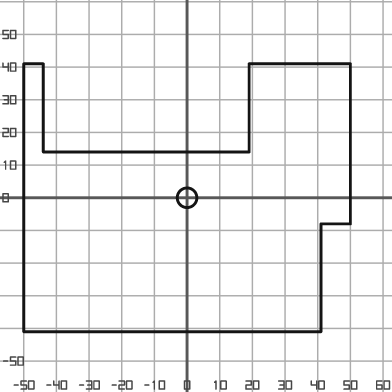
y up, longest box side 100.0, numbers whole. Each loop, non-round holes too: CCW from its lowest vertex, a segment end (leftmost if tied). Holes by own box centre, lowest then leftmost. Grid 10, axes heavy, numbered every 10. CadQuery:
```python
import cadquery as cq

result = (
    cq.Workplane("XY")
    .moveTo(-50.0, -41.0)
    .lineTo(41.0, -41.0)
    .lineTo(41.0, -8.0)
    .lineTo(50.0, -8.0)
    .lineTo(50.0, 41.0)
    .lineTo(19.0, 41.0)
    .lineTo(19.0, 14.0)
    .lineTo(-44.0, 14.0)
    .lineTo(-44.0, 41.0)
    .lineTo(-50.0, 41.0)
    .close()
    .moveTo(0.0, 0.0)
    .circle(3.0)
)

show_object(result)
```